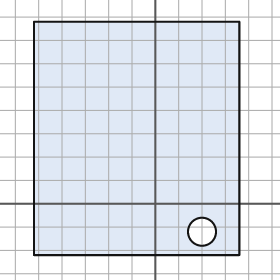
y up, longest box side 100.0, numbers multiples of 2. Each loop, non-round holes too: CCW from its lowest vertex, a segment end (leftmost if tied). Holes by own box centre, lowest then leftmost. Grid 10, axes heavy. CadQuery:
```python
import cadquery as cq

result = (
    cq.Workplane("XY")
    .moveTo(-52.0, -22.0)
    .lineTo(36.0, -22.0)
    .lineTo(36.0, 78.0)
    .lineTo(-52.0, 78.0)
    .close()
    .moveTo(20.0, -12.0)
    .circle(6.0)
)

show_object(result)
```